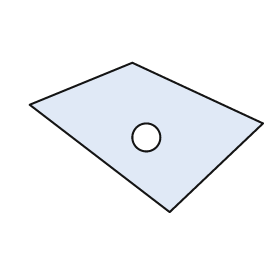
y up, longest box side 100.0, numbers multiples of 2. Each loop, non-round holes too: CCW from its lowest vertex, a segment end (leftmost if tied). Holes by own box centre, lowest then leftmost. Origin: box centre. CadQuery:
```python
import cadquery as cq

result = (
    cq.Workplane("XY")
    .moveTo(10.0, -32.0)
    .lineTo(50.0, 6.0)
    .lineTo(-6.0, 32.0)
    .lineTo(-50.0, 14.0)
    .close()
    .moveTo(0.0, 0.0)
    .circle(6.0)
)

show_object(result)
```